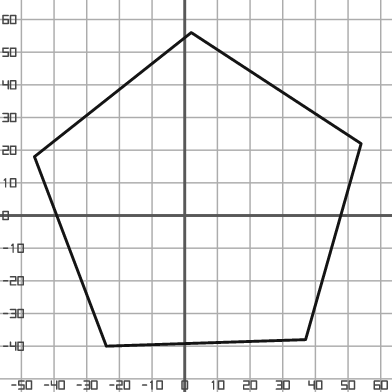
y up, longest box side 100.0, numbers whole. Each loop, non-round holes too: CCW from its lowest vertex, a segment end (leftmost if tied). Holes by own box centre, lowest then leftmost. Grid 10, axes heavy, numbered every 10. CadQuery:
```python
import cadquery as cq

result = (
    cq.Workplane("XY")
    .moveTo(-24.0, -40.0)
    .lineTo(37.0, -38.0)
    .lineTo(54.0, 22.0)
    .lineTo(2.0, 56.0)
    .lineTo(-46.0, 18.0)
    .close()
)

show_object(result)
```